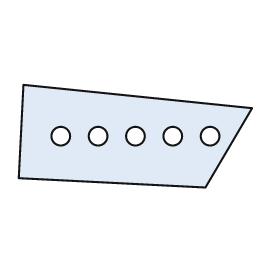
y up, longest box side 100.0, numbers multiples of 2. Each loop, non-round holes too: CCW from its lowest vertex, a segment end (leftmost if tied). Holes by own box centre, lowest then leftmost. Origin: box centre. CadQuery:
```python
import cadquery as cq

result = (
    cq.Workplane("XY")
    .moveTo(30.0, -22.0)
    .lineTo(50.0, 12.0)
    .lineTo(-48.0, 22.0)
    .lineTo(-50.0, -18.0)
    .close()
    .moveTo(-32.0, 0.0)
    .circle(4.0)
    .moveTo(-16.0, 0.0)
    .circle(4.0)
    .moveTo(0.0, 0.0)
    .circle(4.0)
    .moveTo(16.0, 0.0)
    .circle(4.0)
    .moveTo(32.0, 0.0)
    .circle(4.0)
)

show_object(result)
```